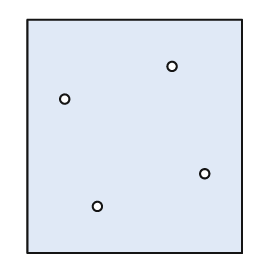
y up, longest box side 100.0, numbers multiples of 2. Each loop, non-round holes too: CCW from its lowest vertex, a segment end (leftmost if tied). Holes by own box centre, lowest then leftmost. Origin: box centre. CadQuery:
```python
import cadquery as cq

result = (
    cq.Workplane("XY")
    .moveTo(-46.0, -50.0)
    .lineTo(46.0, -50.0)
    .lineTo(46.0, 50.0)
    .lineTo(-46.0, 50.0)
    .close()
    .moveTo(-16.0, -30.0)
    .circle(2.0)
    .moveTo(30.0, -16.0)
    .circle(2.0)
    .moveTo(-30.0, 16.0)
    .circle(2.0)
    .moveTo(16.0, 30.0)
    .circle(2.0)
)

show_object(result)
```